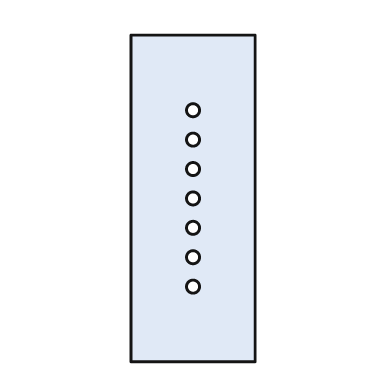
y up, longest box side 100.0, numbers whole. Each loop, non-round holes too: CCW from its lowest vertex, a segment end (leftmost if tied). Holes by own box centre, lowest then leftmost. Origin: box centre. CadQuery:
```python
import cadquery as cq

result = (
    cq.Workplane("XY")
    .moveTo(-19.0, -50.0)
    .lineTo(19.0, -50.0)
    .lineTo(19.0, 50.0)
    .lineTo(-19.0, 50.0)
    .close()
    .moveTo(0.0, -27.0)
    .circle(2.0)
    .moveTo(0.0, -18.0)
    .circle(2.0)
    .moveTo(0.0, -9.0)
    .circle(2.0)
    .moveTo(0.0, 0.0)
    .circle(2.0)
    .moveTo(0.0, 9.0)
    .circle(2.0)
    .moveTo(0.0, 18.0)
    .circle(2.0)
    .moveTo(0.0, 27.0)
    .circle(2.0)
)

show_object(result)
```